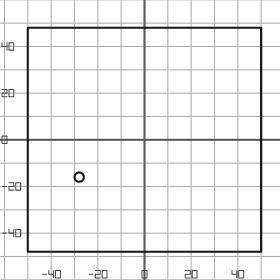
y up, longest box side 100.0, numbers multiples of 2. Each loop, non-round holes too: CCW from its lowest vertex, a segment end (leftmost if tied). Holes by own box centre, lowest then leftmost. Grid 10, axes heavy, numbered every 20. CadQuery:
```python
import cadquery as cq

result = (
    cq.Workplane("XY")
    .moveTo(-50.0, -48.0)
    .lineTo(50.0, -48.0)
    .lineTo(50.0, 48.0)
    .lineTo(-50.0, 48.0)
    .close()
    .moveTo(-28.0, -16.0)
    .circle(2.0)
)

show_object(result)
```